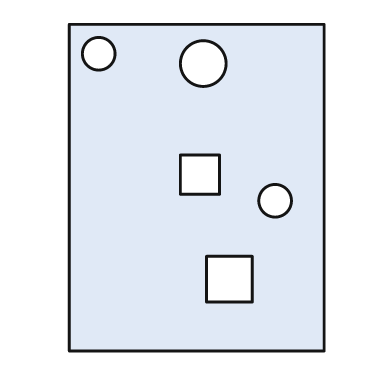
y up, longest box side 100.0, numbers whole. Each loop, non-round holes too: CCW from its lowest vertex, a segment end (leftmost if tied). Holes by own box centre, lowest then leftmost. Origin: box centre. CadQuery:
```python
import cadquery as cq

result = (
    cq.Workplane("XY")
    .moveTo(-39.0, -50.0)
    .lineTo(39.0, -50.0)
    .lineTo(39.0, 50.0)
    .lineTo(-39.0, 50.0)
    .close()
    .moveTo(3.0, -35.0)
    .lineTo(17.0, -35.0)
    .lineTo(17.0, -21.0)
    .lineTo(3.0, -21.0)
    .close()
    .moveTo(24.0, -4.0)
    .circle(5.0)
    .moveTo(-5.0, -2.0)
    .lineTo(7.0, -2.0)
    .lineTo(7.0, 10.0)
    .lineTo(-5.0, 10.0)
    .close()
    .moveTo(2.0, 38.0)
    .circle(7.0)
    .moveTo(-30.0, 41.0)
    .circle(5.0)
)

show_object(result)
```